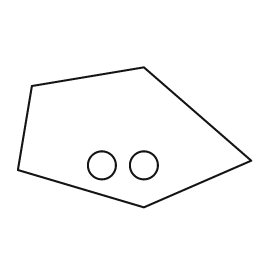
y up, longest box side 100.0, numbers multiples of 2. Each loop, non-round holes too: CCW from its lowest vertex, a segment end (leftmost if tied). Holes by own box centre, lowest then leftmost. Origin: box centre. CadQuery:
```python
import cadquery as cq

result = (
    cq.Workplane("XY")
    .moveTo(4.0, -30.0)
    .lineTo(50.0, -10.0)
    .lineTo(4.0, 30.0)
    .lineTo(-44.0, 22.0)
    .lineTo(-50.0, -14.0)
    .close()
    .moveTo(-14.0, -12.0)
    .circle(6.0)
    .moveTo(4.0, -12.0)
    .circle(6.0)
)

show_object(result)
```